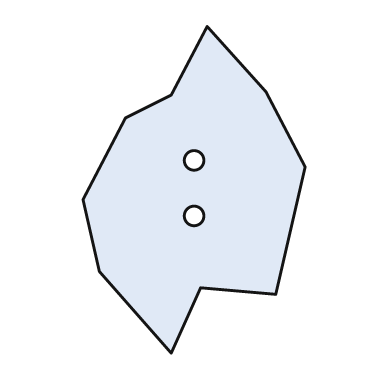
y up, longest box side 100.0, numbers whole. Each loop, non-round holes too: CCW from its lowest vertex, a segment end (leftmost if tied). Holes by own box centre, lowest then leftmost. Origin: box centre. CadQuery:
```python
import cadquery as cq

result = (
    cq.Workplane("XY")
    .moveTo(-7.0, -50.0)
    .lineTo(2.0, -30.0)
    .lineTo(25.0, -32.0)
    .lineTo(34.0, 7.0)
    .lineTo(22.0, 30.0)
    .lineTo(4.0, 50.0)
    .lineTo(-7.0, 29.0)
    .lineTo(-21.0, 22.0)
    .lineTo(-34.0, -3.0)
    .lineTo(-29.0, -25.0)
    .close()
    .moveTo(0.0, -8.0)
    .circle(3.0)
    .moveTo(0.0, 9.0)
    .circle(3.0)
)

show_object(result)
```